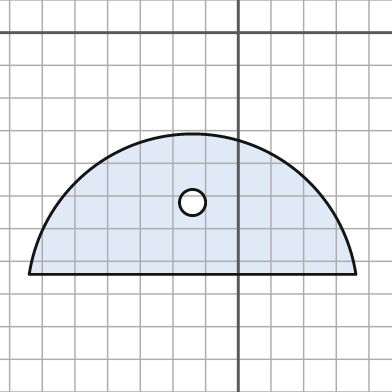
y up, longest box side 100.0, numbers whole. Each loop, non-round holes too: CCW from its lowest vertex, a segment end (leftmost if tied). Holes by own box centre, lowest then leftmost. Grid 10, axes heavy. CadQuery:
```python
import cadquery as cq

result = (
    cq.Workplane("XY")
    .moveTo(-64.0, -74.0)
    .lineTo(36.0, -74.0)
    .threePointArc((-14.0, -31.0), (-64.0, -74.0))
    .close()
    .moveTo(-14.0, -52.0)
    .circle(4.0)
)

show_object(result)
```